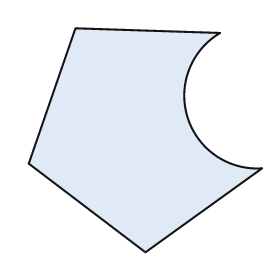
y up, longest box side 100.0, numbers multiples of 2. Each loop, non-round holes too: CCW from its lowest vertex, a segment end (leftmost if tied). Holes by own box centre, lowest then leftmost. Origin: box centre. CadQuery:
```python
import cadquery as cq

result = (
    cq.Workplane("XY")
    .moveTo(0.0, -48.0)
    .lineTo(50.0, -12.0)
    .threePointArc((18.0, 10.0), (32.0, 46.0))
    .lineTo(-30.0, 48.0)
    .lineTo(-50.0, -10.0)
    .close()
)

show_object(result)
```